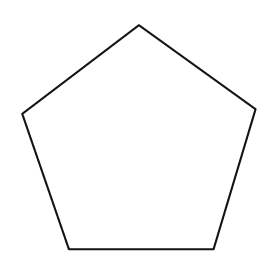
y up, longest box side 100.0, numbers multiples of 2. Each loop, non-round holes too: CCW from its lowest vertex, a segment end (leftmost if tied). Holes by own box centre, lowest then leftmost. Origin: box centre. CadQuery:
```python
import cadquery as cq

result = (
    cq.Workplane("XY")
    .moveTo(-30.0, -48.0)
    .lineTo(32.0, -48.0)
    .lineTo(50.0, 12.0)
    .lineTo(0.0, 48.0)
    .lineTo(-50.0, 10.0)
    .close()
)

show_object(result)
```